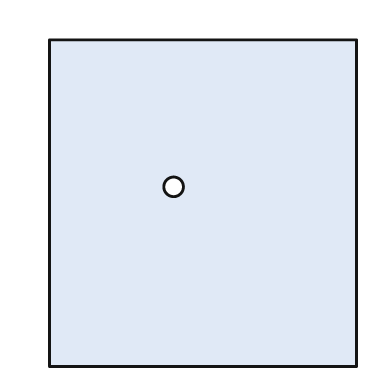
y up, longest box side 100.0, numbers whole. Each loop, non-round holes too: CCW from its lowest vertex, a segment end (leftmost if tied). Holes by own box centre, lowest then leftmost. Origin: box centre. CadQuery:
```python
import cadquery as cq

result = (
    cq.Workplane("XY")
    .moveTo(-47.0, -50.0)
    .lineTo(47.0, -50.0)
    .lineTo(47.0, 50.0)
    .lineTo(-47.0, 50.0)
    .close()
    .moveTo(-9.0, 5.0)
    .circle(3.0)
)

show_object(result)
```